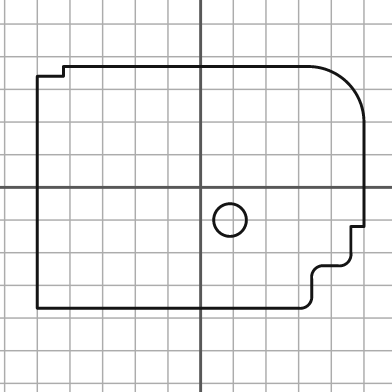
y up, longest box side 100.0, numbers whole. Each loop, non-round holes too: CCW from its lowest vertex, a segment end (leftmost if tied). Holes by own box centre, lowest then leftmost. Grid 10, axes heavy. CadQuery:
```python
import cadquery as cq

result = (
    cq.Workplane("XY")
    .moveTo(-50.0, -37.0)
    .lineTo(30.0, -37.0)
    .threePointArc((33.0, -36.0), (34.0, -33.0))
    .lineTo(34.0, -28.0)
    .threePointArc((35.0, -25.0), (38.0, -24.0))
    .lineTo(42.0, -24.0)
    .threePointArc((45.0, -23.0), (46.0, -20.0))
    .lineTo(46.0, -12.0)
    .lineTo(50.0, -12.0)
    .lineTo(50.0, 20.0)
    .threePointArc((45.0, 32.0), (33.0, 37.0))
    .lineTo(-42.0, 37.0)
    .lineTo(-42.0, 34.0)
    .lineTo(-50.0, 34.0)
    .close()
    .moveTo(9.0, -10.0)
    .circle(5.0)
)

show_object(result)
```